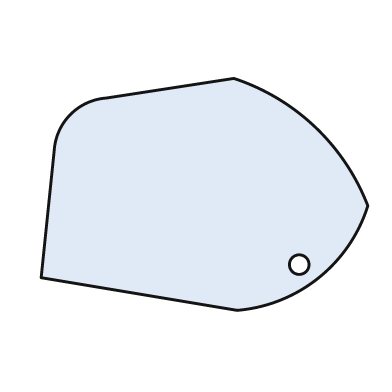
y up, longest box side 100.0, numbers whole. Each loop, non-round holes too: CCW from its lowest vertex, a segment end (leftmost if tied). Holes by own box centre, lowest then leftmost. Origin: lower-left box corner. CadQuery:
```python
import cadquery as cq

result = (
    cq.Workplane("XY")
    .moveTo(60.0, 0.0)
    .threePointArc((85.0, 10.0), (100.0, 32.0))
    .threePointArc((84.0, 56.0), (59.0, 71.0))
    .lineTo(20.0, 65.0)
    .threePointArc((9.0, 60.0), (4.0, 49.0))
    .lineTo(0.0, 10.0)
    .close()
    .moveTo(79.0, 14.0)
    .circle(3.0)
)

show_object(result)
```